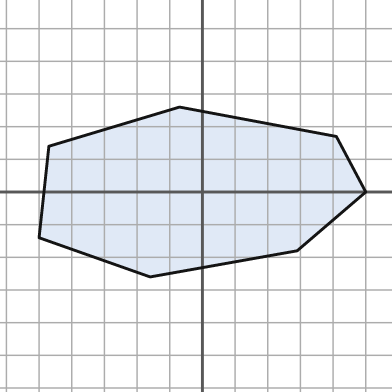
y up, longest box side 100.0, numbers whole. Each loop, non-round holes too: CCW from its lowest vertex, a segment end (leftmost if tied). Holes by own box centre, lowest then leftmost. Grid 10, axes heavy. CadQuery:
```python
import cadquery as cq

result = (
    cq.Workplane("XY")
    .moveTo(-16.0, -26.0)
    .lineTo(29.0, -18.0)
    .lineTo(50.0, 0.0)
    .lineTo(41.0, 17.0)
    .lineTo(-7.0, 26.0)
    .lineTo(-47.0, 14.0)
    .lineTo(-50.0, -14.0)
    .close()
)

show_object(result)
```